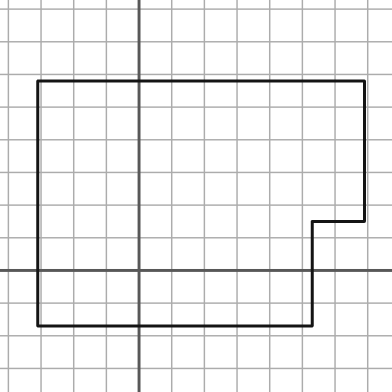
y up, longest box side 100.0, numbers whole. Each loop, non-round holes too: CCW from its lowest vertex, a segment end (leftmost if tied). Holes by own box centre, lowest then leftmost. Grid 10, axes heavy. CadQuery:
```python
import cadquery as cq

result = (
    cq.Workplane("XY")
    .moveTo(-31.0, -17.0)
    .lineTo(53.0, -17.0)
    .lineTo(53.0, 15.0)
    .lineTo(69.0, 15.0)
    .lineTo(69.0, 58.0)
    .lineTo(-31.0, 58.0)
    .close()
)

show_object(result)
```